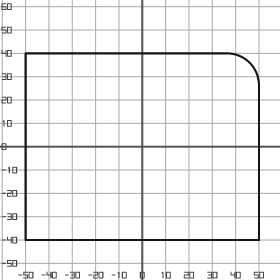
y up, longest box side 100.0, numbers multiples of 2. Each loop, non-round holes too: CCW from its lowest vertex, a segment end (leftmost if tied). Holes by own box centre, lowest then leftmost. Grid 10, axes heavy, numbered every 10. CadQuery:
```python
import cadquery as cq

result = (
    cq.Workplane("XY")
    .moveTo(-50.0, -40.0)
    .lineTo(50.0, -40.0)
    .lineTo(50.0, 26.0)
    .threePointArc((46.0, 36.0), (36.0, 40.0))
    .lineTo(-50.0, 40.0)
    .close()
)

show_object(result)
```